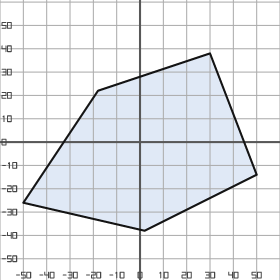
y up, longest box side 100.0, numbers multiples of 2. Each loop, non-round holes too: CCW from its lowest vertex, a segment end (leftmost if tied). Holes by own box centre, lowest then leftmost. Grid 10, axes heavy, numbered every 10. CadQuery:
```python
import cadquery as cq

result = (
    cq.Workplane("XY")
    .moveTo(2.0, -38.0)
    .lineTo(50.0, -14.0)
    .lineTo(30.0, 38.0)
    .lineTo(-18.0, 22.0)
    .lineTo(-50.0, -26.0)
    .close()
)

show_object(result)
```